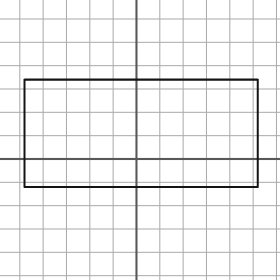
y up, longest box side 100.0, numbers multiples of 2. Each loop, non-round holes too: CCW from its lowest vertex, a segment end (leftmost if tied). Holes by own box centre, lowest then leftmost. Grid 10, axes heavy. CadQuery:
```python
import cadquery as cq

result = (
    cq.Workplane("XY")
    .moveTo(-48.0, -12.0)
    .lineTo(52.0, -12.0)
    .lineTo(52.0, 34.0)
    .lineTo(-48.0, 34.0)
    .close()
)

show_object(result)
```